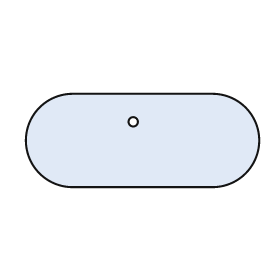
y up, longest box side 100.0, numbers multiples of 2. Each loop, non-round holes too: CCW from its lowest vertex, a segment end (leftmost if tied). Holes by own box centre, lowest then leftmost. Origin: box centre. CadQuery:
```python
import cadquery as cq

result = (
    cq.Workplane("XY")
    .moveTo(-30.0, -20.0)
    .lineTo(30.0, -20.0)
    .threePointArc((50.0, 0.0), (30.0, 20.0))
    .lineTo(-30.0, 20.0)
    .threePointArc((-50.0, 0.0), (-30.0, -20.0))
    .close()
    .moveTo(-4.0, 8.0)
    .circle(2.0)
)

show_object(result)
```